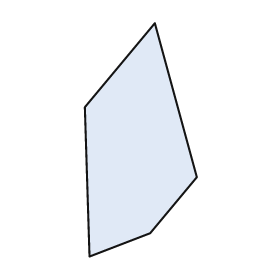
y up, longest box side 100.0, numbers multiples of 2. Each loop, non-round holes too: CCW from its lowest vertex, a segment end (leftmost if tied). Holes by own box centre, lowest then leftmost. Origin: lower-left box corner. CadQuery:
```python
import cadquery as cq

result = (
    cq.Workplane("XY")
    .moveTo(2.0, 0.0)
    .lineTo(28.0, 10.0)
    .lineTo(48.0, 34.0)
    .lineTo(30.0, 100.0)
    .lineTo(0.0, 64.0)
    .close()
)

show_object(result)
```